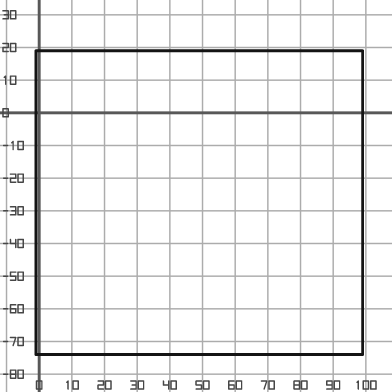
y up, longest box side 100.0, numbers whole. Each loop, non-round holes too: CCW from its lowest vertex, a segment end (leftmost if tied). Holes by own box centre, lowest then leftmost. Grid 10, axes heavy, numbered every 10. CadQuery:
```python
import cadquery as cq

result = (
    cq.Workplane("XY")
    .moveTo(-1.0, -74.0)
    .lineTo(99.0, -74.0)
    .lineTo(99.0, 19.0)
    .lineTo(-1.0, 19.0)
    .close()
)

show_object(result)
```